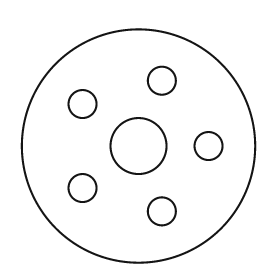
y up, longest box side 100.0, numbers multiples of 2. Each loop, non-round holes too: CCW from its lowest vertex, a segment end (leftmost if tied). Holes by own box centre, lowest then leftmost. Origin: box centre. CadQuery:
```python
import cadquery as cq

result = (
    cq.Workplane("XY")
    .moveTo(0.0, 0.0)
    .circle(50.0)
    .moveTo(10.0, -28.0)
    .circle(6.0)
    .moveTo(-24.0, -18.0)
    .circle(6.0)
    .moveTo(0.0, 0.0)
    .circle(12.0)
    .moveTo(30.0, 0.0)
    .circle(6.0)
    .moveTo(-24.0, 18.0)
    .circle(6.0)
    .moveTo(10.0, 28.0)
    .circle(6.0)
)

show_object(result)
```